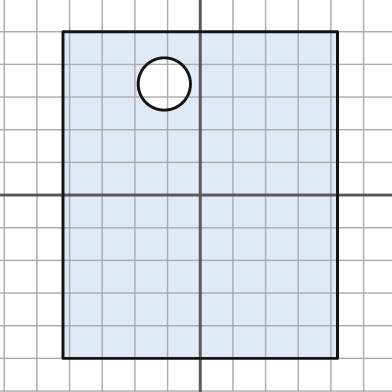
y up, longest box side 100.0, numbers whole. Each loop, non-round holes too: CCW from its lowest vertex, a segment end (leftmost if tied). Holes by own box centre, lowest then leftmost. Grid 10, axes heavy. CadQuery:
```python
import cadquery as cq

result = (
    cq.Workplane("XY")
    .moveTo(-42.0, -50.0)
    .lineTo(42.0, -50.0)
    .lineTo(42.0, 50.0)
    .lineTo(-42.0, 50.0)
    .close()
    .moveTo(-11.0, 34.0)
    .circle(8.0)
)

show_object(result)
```